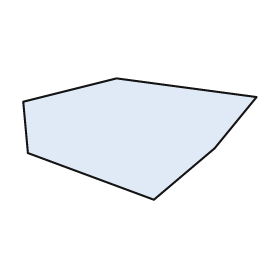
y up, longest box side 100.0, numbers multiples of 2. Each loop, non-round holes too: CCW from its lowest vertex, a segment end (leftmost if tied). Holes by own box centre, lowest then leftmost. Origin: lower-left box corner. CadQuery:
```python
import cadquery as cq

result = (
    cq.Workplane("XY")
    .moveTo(56.0, 0.0)
    .lineTo(82.0, 22.0)
    .lineTo(100.0, 44.0)
    .lineTo(40.0, 52.0)
    .lineTo(0.0, 42.0)
    .lineTo(2.0, 20.0)
    .close()
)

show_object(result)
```